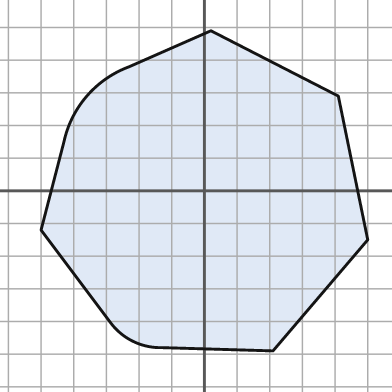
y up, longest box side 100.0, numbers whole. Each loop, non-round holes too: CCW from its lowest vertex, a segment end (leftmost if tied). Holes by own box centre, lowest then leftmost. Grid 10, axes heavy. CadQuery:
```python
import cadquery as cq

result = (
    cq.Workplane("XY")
    .moveTo(21.0, -49.0)
    .lineTo(50.0, -15.0)
    .lineTo(41.0, 29.0)
    .lineTo(2.0, 49.0)
    .lineTo(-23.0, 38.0)
    .threePointArc((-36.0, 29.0), (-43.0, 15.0))
    .lineTo(-50.0, -12.0)
    .lineTo(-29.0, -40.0)
    .threePointArc((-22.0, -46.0), (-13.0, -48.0))
    .close()
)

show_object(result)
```